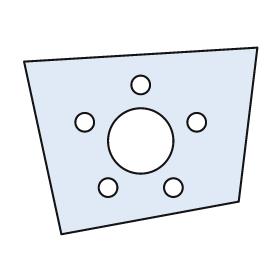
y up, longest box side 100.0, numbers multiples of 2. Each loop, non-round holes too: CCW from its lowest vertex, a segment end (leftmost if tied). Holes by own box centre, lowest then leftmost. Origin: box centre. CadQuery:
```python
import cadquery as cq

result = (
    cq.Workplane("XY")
    .moveTo(-34.0, -40.0)
    .lineTo(42.0, -26.0)
    .lineTo(50.0, 40.0)
    .lineTo(-50.0, 34.0)
    .close()
    .moveTo(-14.0, -20.0)
    .circle(4.0)
    .moveTo(14.0, -20.0)
    .circle(4.0)
    .moveTo(0.0, 0.0)
    .circle(14.0)
    .moveTo(-24.0, 8.0)
    .circle(4.0)
    .moveTo(24.0, 8.0)
    .circle(4.0)
    .moveTo(0.0, 24.0)
    .circle(4.0)
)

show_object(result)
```